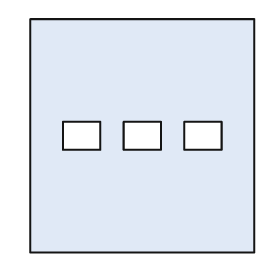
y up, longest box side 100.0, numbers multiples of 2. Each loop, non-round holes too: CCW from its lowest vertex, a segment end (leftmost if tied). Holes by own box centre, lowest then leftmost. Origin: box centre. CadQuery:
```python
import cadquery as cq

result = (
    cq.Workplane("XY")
    .moveTo(-48.0, -50.0)
    .lineTo(48.0, -50.0)
    .lineTo(48.0, 50.0)
    .lineTo(-48.0, 50.0)
    .close()
    .moveTo(-34.0, -6.0)
    .lineTo(-18.0, -6.0)
    .lineTo(-18.0, 6.0)
    .lineTo(-34.0, 6.0)
    .close()
    .moveTo(-8.0, -6.0)
    .lineTo(8.0, -6.0)
    .lineTo(8.0, 6.0)
    .lineTo(-8.0, 6.0)
    .close()
    .moveTo(18.0, -6.0)
    .lineTo(34.0, -6.0)
    .lineTo(34.0, 6.0)
    .lineTo(18.0, 6.0)
    .close()
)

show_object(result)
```